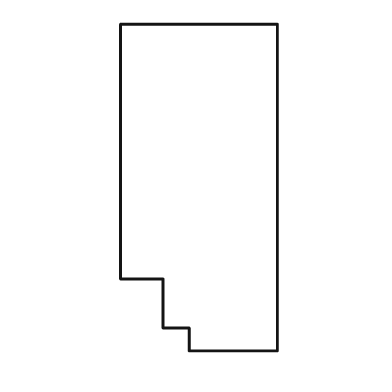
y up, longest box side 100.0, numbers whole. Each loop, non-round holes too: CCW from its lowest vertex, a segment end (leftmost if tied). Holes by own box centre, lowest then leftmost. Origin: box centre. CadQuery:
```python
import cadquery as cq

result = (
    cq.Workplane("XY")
    .moveTo(-3.0, -50.0)
    .lineTo(24.0, -50.0)
    .lineTo(24.0, 50.0)
    .lineTo(-24.0, 50.0)
    .lineTo(-24.0, -28.0)
    .lineTo(-11.0, -28.0)
    .lineTo(-11.0, -43.0)
    .lineTo(-3.0, -43.0)
    .close()
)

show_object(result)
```